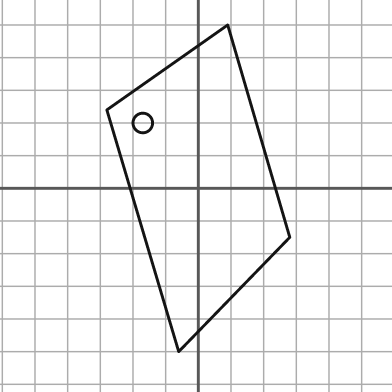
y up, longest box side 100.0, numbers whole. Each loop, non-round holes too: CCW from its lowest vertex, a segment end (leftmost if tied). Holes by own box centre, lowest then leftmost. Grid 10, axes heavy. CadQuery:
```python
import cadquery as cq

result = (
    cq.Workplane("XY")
    .moveTo(-6.0, -50.0)
    .lineTo(28.0, -15.0)
    .lineTo(9.0, 50.0)
    .lineTo(-28.0, 24.0)
    .close()
    .moveTo(-17.0, 20.0)
    .circle(3.0)
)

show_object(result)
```